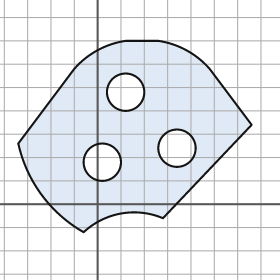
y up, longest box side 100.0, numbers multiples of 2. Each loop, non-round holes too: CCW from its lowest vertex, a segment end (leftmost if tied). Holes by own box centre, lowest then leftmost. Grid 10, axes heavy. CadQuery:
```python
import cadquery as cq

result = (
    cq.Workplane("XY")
    .moveTo(-6.0, -12.0)
    .threePointArc((10.0, -4.0), (28.0, -6.0))
    .lineTo(66.0, 34.0)
    .lineTo(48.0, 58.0)
    .threePointArc((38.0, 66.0), (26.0, 70.0))
    .lineTo(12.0, 70.0)
    .threePointArc((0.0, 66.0), (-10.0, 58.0))
    .lineTo(-34.0, 26.0)
    .threePointArc((-24.0, 4.0), (-6.0, -12.0))
    .close()
    .moveTo(2.0, 18.0)
    .circle(8.0)
    .moveTo(34.0, 24.0)
    .circle(8.0)
    .moveTo(12.0, 48.0)
    .circle(8.0)
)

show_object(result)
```